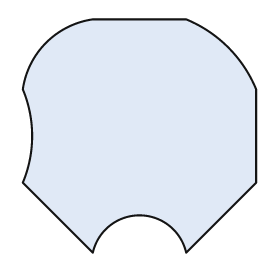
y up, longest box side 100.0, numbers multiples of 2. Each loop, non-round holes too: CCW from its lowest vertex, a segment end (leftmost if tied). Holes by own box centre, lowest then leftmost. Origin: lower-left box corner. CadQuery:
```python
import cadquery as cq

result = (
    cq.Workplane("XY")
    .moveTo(30.0, 0.0)
    .threePointArc((50.0, 16.0), (70.0, 0.0))
    .lineTo(100.0, 30.0)
    .lineTo(100.0, 70.0)
    .threePointArc((88.0, 88.0), (70.0, 100.0))
    .lineTo(30.0, 100.0)
    .threePointArc((10.0, 90.0), (0.0, 70.0))
    .threePointArc((4.0, 50.0), (0.0, 30.0))
    .close()
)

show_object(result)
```